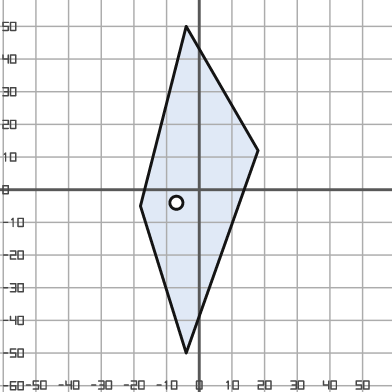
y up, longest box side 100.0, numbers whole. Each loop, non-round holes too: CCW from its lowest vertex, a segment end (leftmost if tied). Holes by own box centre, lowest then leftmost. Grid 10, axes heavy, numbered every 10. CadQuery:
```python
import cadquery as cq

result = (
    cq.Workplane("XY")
    .moveTo(-4.0, -50.0)
    .lineTo(18.0, 12.0)
    .lineTo(-4.0, 50.0)
    .lineTo(-18.0, -5.0)
    .close()
    .moveTo(-7.0, -4.0)
    .circle(2.0)
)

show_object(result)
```